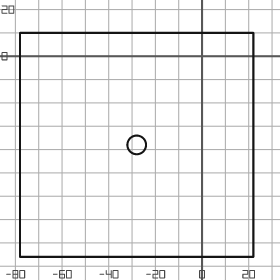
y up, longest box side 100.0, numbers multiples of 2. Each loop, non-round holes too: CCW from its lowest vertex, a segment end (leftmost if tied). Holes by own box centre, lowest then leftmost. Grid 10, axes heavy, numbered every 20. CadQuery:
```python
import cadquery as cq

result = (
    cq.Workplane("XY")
    .moveTo(-78.0, -86.0)
    .lineTo(22.0, -86.0)
    .lineTo(22.0, 10.0)
    .lineTo(-78.0, 10.0)
    .close()
    .moveTo(-28.0, -38.0)
    .circle(4.0)
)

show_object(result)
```